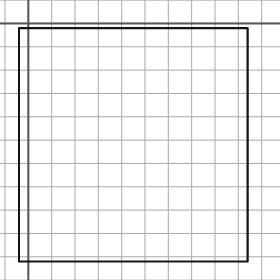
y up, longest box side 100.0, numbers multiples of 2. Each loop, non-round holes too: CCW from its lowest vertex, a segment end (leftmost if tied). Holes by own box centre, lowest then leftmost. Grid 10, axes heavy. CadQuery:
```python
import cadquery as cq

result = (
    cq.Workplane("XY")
    .moveTo(-4.0, -102.0)
    .lineTo(94.0, -102.0)
    .lineTo(94.0, -2.0)
    .lineTo(-4.0, -2.0)
    .close()
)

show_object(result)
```